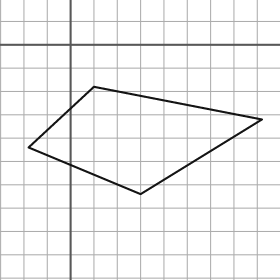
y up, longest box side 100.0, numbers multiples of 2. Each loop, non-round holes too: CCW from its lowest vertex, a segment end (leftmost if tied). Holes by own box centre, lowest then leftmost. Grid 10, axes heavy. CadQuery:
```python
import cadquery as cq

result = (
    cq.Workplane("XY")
    .moveTo(30.0, -64.0)
    .lineTo(82.0, -32.0)
    .lineTo(10.0, -18.0)
    .lineTo(-18.0, -44.0)
    .close()
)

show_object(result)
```